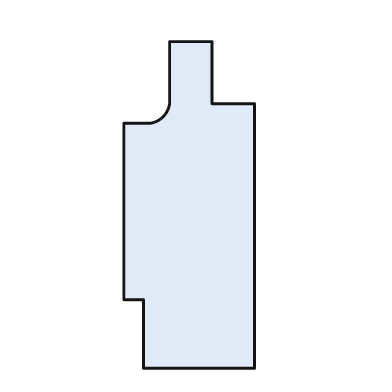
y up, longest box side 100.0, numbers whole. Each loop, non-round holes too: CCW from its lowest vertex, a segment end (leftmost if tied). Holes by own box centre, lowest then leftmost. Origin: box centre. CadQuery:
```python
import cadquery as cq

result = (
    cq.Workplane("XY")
    .moveTo(-14.0, -50.0)
    .lineTo(20.0, -50.0)
    .lineTo(20.0, 31.0)
    .lineTo(7.0, 31.0)
    .lineTo(7.0, 50.0)
    .lineTo(-6.0, 50.0)
    .lineTo(-6.0, 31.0)
    .threePointArc((-8.0, 27.0), (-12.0, 25.0))
    .lineTo(-20.0, 25.0)
    .lineTo(-20.0, -29.0)
    .lineTo(-14.0, -29.0)
    .close()
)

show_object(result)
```